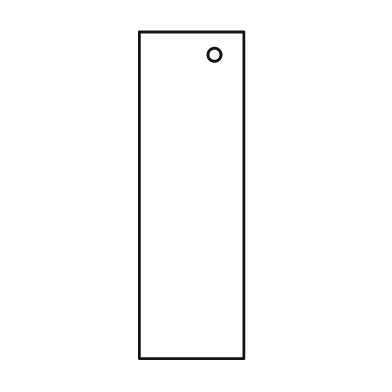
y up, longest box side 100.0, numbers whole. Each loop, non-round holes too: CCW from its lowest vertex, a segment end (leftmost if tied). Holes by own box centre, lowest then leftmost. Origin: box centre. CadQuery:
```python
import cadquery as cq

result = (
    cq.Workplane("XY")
    .moveTo(-16.0, -50.0)
    .lineTo(16.0, -50.0)
    .lineTo(16.0, 50.0)
    .lineTo(-16.0, 50.0)
    .close()
    .moveTo(7.0, 43.0)
    .circle(2.0)
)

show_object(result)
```